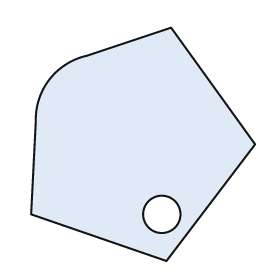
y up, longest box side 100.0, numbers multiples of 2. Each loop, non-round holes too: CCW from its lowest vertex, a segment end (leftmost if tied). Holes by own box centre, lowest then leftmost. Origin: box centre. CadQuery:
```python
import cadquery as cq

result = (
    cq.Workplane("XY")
    .moveTo(10.0, -50.0)
    .lineTo(48.0, 0.0)
    .lineTo(12.0, 50.0)
    .lineTo(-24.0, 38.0)
    .threePointArc((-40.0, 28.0), (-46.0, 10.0))
    .lineTo(-48.0, -30.0)
    .close()
    .moveTo(8.0, -30.0)
    .circle(8.0)
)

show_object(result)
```